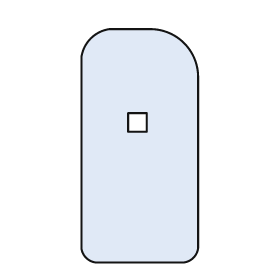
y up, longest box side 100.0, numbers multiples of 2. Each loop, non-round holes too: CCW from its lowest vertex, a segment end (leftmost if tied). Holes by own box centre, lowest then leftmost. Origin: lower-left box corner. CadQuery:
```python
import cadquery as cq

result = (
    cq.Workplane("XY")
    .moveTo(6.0, 0.0)
    .lineTo(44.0, 0.0)
    .threePointArc((48.0, 2.0), (50.0, 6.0))
    .lineTo(50.0, 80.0)
    .threePointArc((44.0, 94.0), (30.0, 100.0))
    .lineTo(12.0, 100.0)
    .threePointArc((4.0, 96.0), (0.0, 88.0))
    .lineTo(0.0, 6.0)
    .threePointArc((2.0, 2.0), (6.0, 0.0))
    .close()
    .moveTo(20.0, 56.0)
    .lineTo(28.0, 56.0)
    .lineTo(28.0, 64.0)
    .lineTo(20.0, 64.0)
    .close()
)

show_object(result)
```